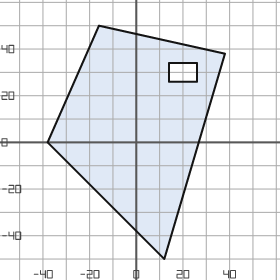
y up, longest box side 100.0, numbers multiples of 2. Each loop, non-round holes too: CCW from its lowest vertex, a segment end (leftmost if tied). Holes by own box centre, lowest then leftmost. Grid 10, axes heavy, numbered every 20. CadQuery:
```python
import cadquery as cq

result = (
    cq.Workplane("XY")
    .moveTo(12.0, -50.0)
    .lineTo(38.0, 38.0)
    .lineTo(-16.0, 50.0)
    .lineTo(-38.0, 0.0)
    .close()
    .moveTo(14.0, 26.0)
    .lineTo(26.0, 26.0)
    .lineTo(26.0, 34.0)
    .lineTo(14.0, 34.0)
    .close()
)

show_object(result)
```